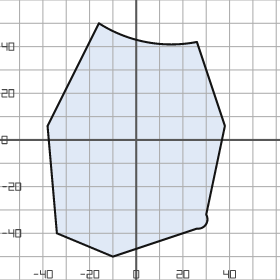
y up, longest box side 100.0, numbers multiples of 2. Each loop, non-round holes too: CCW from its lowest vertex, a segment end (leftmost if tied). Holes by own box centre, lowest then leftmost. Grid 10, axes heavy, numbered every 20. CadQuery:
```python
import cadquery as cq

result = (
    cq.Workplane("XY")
    .moveTo(-10.0, -50.0)
    .lineTo(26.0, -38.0)
    .threePointArc((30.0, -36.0), (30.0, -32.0))
    .lineTo(38.0, 6.0)
    .lineTo(26.0, 42.0)
    .threePointArc((4.0, 42.0), (-16.0, 50.0))
    .lineTo(-38.0, 6.0)
    .lineTo(-34.0, -40.0)
    .close()
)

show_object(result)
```